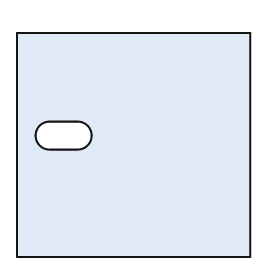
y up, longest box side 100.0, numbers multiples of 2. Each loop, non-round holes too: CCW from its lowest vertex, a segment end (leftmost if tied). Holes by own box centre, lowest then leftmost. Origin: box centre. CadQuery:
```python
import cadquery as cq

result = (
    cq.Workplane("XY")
    .moveTo(-50.0, -48.0)
    .lineTo(50.0, -48.0)
    .lineTo(50.0, 48.0)
    .lineTo(-50.0, 48.0)
    .close()
    .moveTo(-36.0, -2.0)
    .lineTo(-24.0, -2.0)
    .threePointArc((-18.0, 4.0), (-24.0, 10.0))
    .lineTo(-36.0, 10.0)
    .threePointArc((-42.0, 4.0), (-36.0, -2.0))
    .close()
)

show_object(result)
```